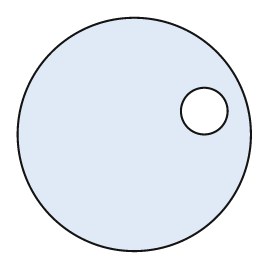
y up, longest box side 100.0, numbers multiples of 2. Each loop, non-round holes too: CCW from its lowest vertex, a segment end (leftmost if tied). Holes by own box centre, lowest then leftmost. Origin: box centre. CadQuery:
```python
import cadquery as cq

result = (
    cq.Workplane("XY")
    .moveTo(0.0, 0.0)
    .circle(50.0)
    .moveTo(30.0, 10.0)
    .circle(10.0)
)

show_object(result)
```